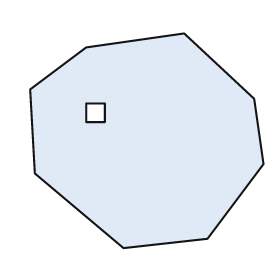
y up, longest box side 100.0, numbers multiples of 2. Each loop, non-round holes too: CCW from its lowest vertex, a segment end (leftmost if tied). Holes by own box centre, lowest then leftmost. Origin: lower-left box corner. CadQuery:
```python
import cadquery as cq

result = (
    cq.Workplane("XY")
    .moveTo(40.0, 0.0)
    .lineTo(76.0, 4.0)
    .lineTo(100.0, 36.0)
    .lineTo(96.0, 64.0)
    .lineTo(66.0, 92.0)
    .lineTo(24.0, 86.0)
    .lineTo(0.0, 68.0)
    .lineTo(2.0, 32.0)
    .close()
    .moveTo(24.0, 54.0)
    .lineTo(32.0, 54.0)
    .lineTo(32.0, 62.0)
    .lineTo(24.0, 62.0)
    .close()
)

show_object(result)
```